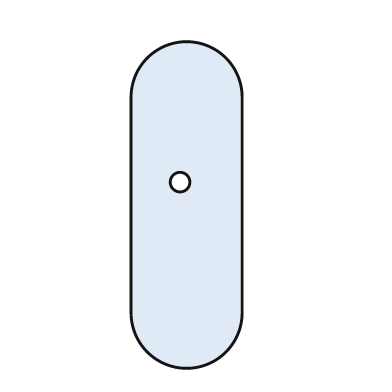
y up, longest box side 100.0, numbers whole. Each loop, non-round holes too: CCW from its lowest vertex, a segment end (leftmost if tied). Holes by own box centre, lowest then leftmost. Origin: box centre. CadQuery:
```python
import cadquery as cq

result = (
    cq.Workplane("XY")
    .moveTo(-17.0, -33.0)
    .threePointArc((0.0, -50.0), (17.0, -33.0))
    .lineTo(17.0, 33.0)
    .threePointArc((0.0, 50.0), (-17.0, 33.0))
    .close()
    .moveTo(-2.0, 7.0)
    .circle(3.0)
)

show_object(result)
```